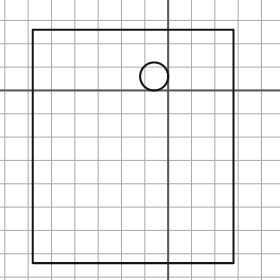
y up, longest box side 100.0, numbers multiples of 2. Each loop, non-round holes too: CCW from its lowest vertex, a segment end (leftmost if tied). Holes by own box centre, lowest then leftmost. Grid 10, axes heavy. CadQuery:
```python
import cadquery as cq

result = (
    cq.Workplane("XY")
    .moveTo(-58.0, -74.0)
    .lineTo(28.0, -74.0)
    .lineTo(28.0, 26.0)
    .lineTo(-58.0, 26.0)
    .close()
    .moveTo(-6.0, 6.0)
    .circle(6.0)
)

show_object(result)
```